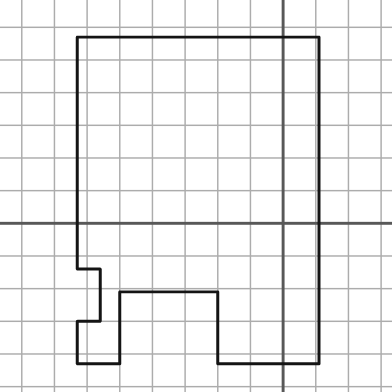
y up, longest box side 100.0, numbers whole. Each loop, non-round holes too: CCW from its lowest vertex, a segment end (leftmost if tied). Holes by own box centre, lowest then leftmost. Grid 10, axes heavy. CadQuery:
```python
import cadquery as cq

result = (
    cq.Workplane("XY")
    .moveTo(-63.0, -43.0)
    .lineTo(-50.0, -43.0)
    .lineTo(-50.0, -21.0)
    .lineTo(-20.0, -21.0)
    .lineTo(-20.0, -43.0)
    .lineTo(11.0, -43.0)
    .lineTo(11.0, 57.0)
    .lineTo(-63.0, 57.0)
    .lineTo(-63.0, -14.0)
    .lineTo(-56.0, -14.0)
    .lineTo(-56.0, -30.0)
    .lineTo(-63.0, -30.0)
    .close()
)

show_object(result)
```